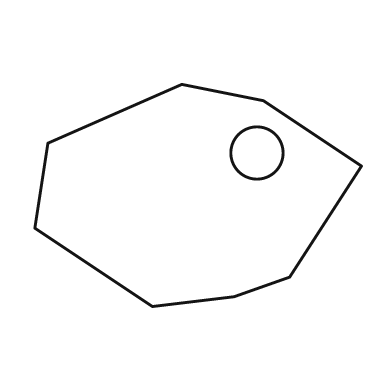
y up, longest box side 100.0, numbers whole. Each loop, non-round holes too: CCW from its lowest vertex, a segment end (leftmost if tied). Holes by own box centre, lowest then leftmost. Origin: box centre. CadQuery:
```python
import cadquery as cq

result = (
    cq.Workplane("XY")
    .moveTo(-14.0, -34.0)
    .lineTo(11.0, -31.0)
    .lineTo(28.0, -25.0)
    .lineTo(50.0, 9.0)
    .lineTo(20.0, 29.0)
    .lineTo(-5.0, 34.0)
    .lineTo(-46.0, 16.0)
    .lineTo(-50.0, -10.0)
    .close()
    .moveTo(18.0, 13.0)
    .circle(8.0)
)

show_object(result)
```